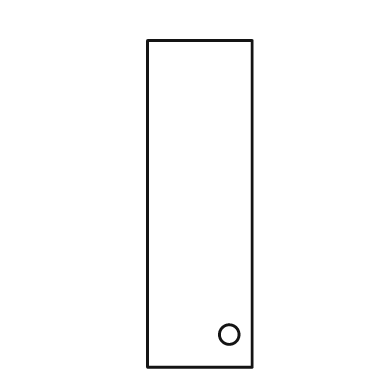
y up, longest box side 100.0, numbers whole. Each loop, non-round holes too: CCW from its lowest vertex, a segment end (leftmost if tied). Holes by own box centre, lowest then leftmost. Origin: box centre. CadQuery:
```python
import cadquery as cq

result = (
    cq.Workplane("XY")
    .moveTo(-16.0, -50.0)
    .lineTo(16.0, -50.0)
    .lineTo(16.0, 50.0)
    .lineTo(-16.0, 50.0)
    .close()
    .moveTo(9.0, -40.0)
    .circle(3.0)
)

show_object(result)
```